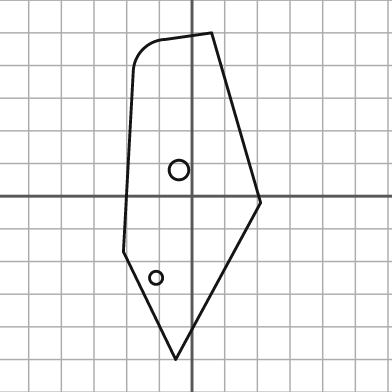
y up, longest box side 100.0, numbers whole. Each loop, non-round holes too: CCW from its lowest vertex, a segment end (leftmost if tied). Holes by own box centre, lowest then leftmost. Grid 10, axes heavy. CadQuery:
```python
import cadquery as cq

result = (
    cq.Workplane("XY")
    .moveTo(-5.0, -50.0)
    .lineTo(21.0, -2.0)
    .lineTo(6.0, 50.0)
    .lineTo(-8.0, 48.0)
    .threePointArc((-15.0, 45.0), (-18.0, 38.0))
    .lineTo(-21.0, -17.0)
    .close()
    .moveTo(-11.0, -25.0)
    .circle(2.0)
    .moveTo(-4.0, 8.0)
    .circle(3.0)
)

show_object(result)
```